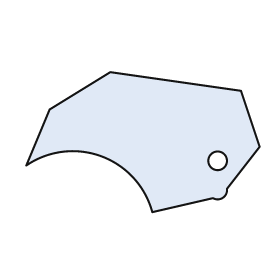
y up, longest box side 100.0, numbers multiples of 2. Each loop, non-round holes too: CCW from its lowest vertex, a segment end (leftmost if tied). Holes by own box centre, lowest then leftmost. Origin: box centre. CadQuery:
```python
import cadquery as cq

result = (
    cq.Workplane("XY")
    .moveTo(4.0, -30.0)
    .lineTo(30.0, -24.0)
    .threePointArc((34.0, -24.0), (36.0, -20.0))
    .lineTo(50.0, -2.0)
    .lineTo(42.0, 22.0)
    .lineTo(-14.0, 30.0)
    .lineTo(-40.0, 14.0)
    .lineTo(-50.0, -10.0)
    .threePointArc((-18.0, -6.0), (4.0, -30.0))
    .close()
    .moveTo(32.0, -8.0)
    .circle(4.0)
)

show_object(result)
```